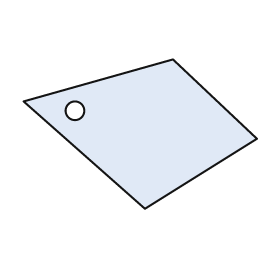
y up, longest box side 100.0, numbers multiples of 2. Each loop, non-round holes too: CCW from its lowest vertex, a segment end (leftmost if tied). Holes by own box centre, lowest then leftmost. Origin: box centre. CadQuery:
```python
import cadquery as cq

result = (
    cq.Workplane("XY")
    .moveTo(2.0, -32.0)
    .lineTo(50.0, -2.0)
    .lineTo(14.0, 32.0)
    .lineTo(-50.0, 14.0)
    .close()
    .moveTo(-28.0, 10.0)
    .circle(4.0)
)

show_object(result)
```